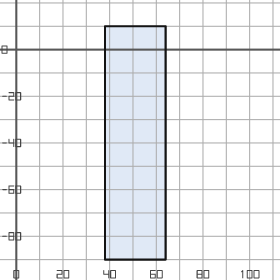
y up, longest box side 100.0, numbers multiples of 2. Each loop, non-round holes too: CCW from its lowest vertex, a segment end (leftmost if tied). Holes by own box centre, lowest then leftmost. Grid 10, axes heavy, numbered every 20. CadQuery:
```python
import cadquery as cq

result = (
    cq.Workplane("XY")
    .moveTo(38.0, -90.0)
    .lineTo(64.0, -90.0)
    .lineTo(64.0, 10.0)
    .lineTo(38.0, 10.0)
    .close()
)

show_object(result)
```